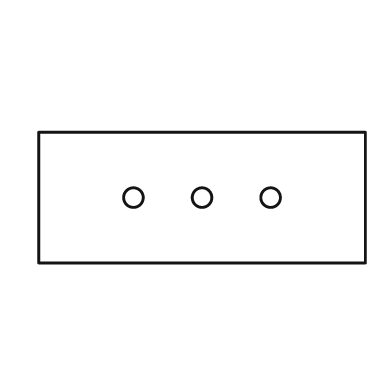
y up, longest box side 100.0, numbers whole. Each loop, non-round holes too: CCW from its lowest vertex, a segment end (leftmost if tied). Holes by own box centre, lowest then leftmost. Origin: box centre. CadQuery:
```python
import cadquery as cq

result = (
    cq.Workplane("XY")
    .moveTo(-50.0, -20.0)
    .lineTo(50.0, -20.0)
    .lineTo(50.0, 20.0)
    .lineTo(-50.0, 20.0)
    .close()
    .moveTo(-21.0, 0.0)
    .circle(3.0)
    .moveTo(0.0, 0.0)
    .circle(3.0)
    .moveTo(21.0, 0.0)
    .circle(3.0)
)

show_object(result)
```